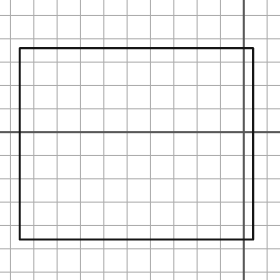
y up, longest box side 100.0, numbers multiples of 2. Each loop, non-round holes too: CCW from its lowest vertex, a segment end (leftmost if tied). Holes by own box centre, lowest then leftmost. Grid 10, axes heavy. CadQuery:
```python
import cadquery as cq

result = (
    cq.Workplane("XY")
    .moveTo(-96.0, -46.0)
    .lineTo(4.0, -46.0)
    .lineTo(4.0, 36.0)
    .lineTo(-96.0, 36.0)
    .close()
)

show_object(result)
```